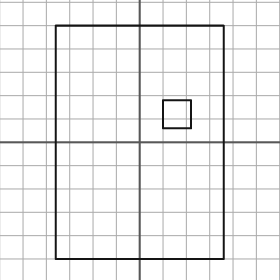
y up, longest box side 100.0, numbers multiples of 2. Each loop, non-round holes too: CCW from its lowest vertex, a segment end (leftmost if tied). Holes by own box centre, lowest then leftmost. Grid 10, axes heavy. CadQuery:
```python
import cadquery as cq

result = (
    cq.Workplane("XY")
    .moveTo(-36.0, -50.0)
    .lineTo(36.0, -50.0)
    .lineTo(36.0, 50.0)
    .lineTo(-36.0, 50.0)
    .close()
    .moveTo(10.0, 6.0)
    .lineTo(22.0, 6.0)
    .lineTo(22.0, 18.0)
    .lineTo(10.0, 18.0)
    .close()
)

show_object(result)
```